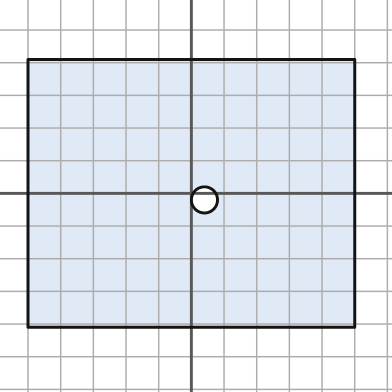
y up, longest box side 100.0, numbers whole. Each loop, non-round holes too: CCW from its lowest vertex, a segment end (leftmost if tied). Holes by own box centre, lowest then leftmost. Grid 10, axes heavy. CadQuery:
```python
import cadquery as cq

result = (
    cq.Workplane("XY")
    .moveTo(-50.0, -41.0)
    .lineTo(50.0, -41.0)
    .lineTo(50.0, 41.0)
    .lineTo(-50.0, 41.0)
    .close()
    .moveTo(4.0, -2.0)
    .circle(4.0)
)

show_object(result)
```